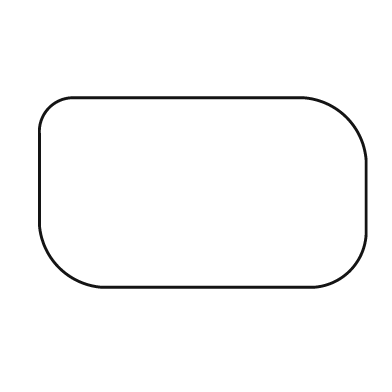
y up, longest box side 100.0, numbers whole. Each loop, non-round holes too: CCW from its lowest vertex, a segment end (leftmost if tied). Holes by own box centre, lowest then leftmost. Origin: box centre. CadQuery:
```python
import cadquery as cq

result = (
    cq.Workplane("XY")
    .moveTo(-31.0, -29.0)
    .lineTo(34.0, -29.0)
    .threePointArc((45.0, -24.0), (50.0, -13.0))
    .lineTo(50.0, 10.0)
    .threePointArc((44.0, 23.0), (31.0, 29.0))
    .lineTo(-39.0, 29.0)
    .threePointArc((-47.0, 26.0), (-50.0, 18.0))
    .lineTo(-50.0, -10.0)
    .threePointArc((-44.0, -23.0), (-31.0, -29.0))
    .close()
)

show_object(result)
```